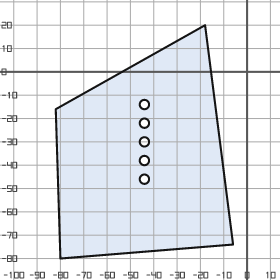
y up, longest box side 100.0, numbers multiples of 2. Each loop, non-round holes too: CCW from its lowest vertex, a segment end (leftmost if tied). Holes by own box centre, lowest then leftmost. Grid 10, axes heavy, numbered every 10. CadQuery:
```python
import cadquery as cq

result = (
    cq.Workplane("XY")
    .moveTo(-80.0, -80.0)
    .lineTo(-6.0, -74.0)
    .lineTo(-18.0, 20.0)
    .lineTo(-82.0, -16.0)
    .close()
    .moveTo(-44.0, -46.0)
    .circle(2.0)
    .moveTo(-44.0, -38.0)
    .circle(2.0)
    .moveTo(-44.0, -30.0)
    .circle(2.0)
    .moveTo(-44.0, -22.0)
    .circle(2.0)
    .moveTo(-44.0, -14.0)
    .circle(2.0)
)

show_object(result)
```